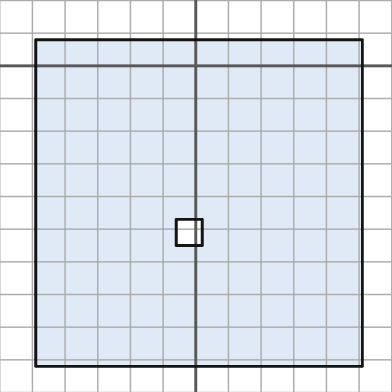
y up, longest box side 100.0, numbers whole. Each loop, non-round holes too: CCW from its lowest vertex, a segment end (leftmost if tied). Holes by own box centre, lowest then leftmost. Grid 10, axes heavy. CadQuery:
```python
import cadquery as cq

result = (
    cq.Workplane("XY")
    .moveTo(-49.0, -92.0)
    .lineTo(51.0, -92.0)
    .lineTo(51.0, 8.0)
    .lineTo(-49.0, 8.0)
    .close()
    .moveTo(-6.0, -55.0)
    .lineTo(2.0, -55.0)
    .lineTo(2.0, -47.0)
    .lineTo(-6.0, -47.0)
    .close()
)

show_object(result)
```